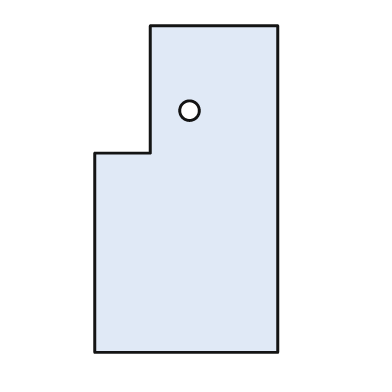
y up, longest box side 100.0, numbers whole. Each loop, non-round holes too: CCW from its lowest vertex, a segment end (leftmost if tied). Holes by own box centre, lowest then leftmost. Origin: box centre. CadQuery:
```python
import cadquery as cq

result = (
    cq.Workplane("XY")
    .moveTo(-28.0, -50.0)
    .lineTo(28.0, -50.0)
    .lineTo(28.0, 50.0)
    .lineTo(-11.0, 50.0)
    .lineTo(-11.0, 11.0)
    .lineTo(-28.0, 11.0)
    .close()
    .moveTo(1.0, 24.0)
    .circle(3.0)
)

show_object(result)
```